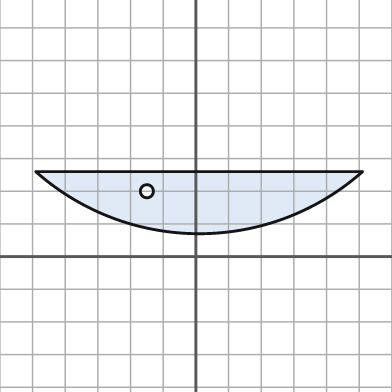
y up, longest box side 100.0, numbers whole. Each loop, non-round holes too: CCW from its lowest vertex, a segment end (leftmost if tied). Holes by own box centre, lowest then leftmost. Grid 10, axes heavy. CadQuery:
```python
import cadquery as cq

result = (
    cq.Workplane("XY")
    .moveTo(-49.0, 26.0)
    .threePointArc((1.0, 7.0), (51.0, 26.0))
    .close()
    .moveTo(-15.0, 20.0)
    .circle(2.0)
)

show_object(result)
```